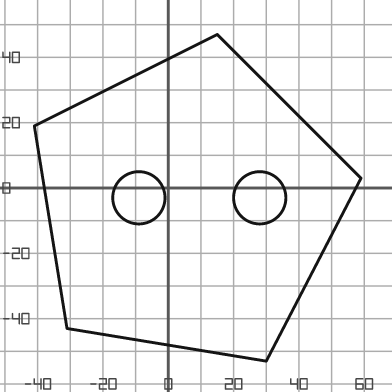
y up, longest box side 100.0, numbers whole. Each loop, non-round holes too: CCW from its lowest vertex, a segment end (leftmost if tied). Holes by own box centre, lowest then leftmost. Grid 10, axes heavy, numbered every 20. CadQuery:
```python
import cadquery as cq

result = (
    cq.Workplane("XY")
    .moveTo(30.0, -53.0)
    .lineTo(59.0, 3.0)
    .lineTo(15.0, 47.0)
    .lineTo(-41.0, 19.0)
    .lineTo(-31.0, -43.0)
    .close()
    .moveTo(-9.0, -3.0)
    .circle(8.0)
    .moveTo(28.0, -3.0)
    .circle(8.0)
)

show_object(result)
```